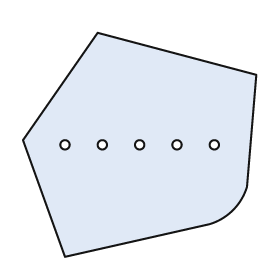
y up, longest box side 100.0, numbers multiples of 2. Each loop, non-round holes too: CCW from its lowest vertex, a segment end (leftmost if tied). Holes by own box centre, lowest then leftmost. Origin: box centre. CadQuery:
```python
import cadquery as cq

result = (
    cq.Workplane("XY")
    .moveTo(-32.0, -48.0)
    .lineTo(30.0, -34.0)
    .threePointArc((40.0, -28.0), (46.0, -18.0))
    .lineTo(50.0, 30.0)
    .lineTo(-18.0, 48.0)
    .lineTo(-50.0, 2.0)
    .close()
    .moveTo(-32.0, 0.0)
    .circle(2.0)
    .moveTo(-16.0, 0.0)
    .circle(2.0)
    .moveTo(0.0, 0.0)
    .circle(2.0)
    .moveTo(16.0, 0.0)
    .circle(2.0)
    .moveTo(32.0, 0.0)
    .circle(2.0)
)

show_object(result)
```